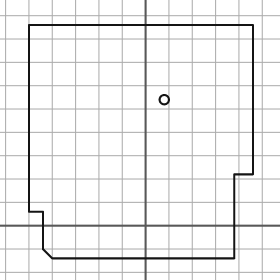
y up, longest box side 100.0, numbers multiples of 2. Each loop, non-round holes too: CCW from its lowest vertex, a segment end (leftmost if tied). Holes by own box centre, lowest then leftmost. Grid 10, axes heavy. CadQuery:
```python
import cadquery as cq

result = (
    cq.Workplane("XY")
    .moveTo(-40.0, -14.0)
    .lineTo(38.0, -14.0)
    .lineTo(38.0, 22.0)
    .lineTo(46.0, 22.0)
    .lineTo(46.0, 86.0)
    .lineTo(-50.0, 86.0)
    .lineTo(-50.0, 6.0)
    .lineTo(-44.0, 6.0)
    .lineTo(-44.0, -10.0)
    .close()
    .moveTo(8.0, 54.0)
    .circle(2.0)
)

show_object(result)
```